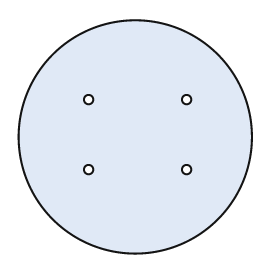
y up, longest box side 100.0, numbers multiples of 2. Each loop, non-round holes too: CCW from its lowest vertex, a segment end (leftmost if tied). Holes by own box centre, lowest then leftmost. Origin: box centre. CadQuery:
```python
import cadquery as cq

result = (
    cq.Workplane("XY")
    .moveTo(0.0, 0.0)
    .circle(50.0)
    .moveTo(-20.0, -14.0)
    .circle(2.0)
    .moveTo(22.0, -14.0)
    .circle(2.0)
    .moveTo(-20.0, 16.0)
    .circle(2.0)
    .moveTo(22.0, 16.0)
    .circle(2.0)
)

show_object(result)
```